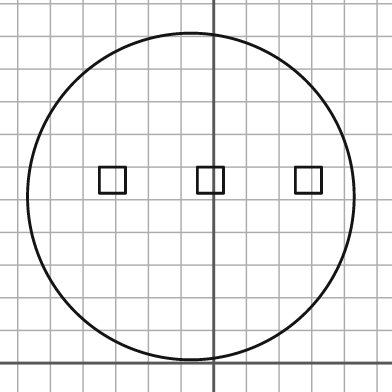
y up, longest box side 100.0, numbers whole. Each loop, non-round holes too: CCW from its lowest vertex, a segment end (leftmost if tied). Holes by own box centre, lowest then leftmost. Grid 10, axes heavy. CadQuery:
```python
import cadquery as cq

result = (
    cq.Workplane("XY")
    .moveTo(-7.0, 51.0)
    .circle(50.0)
    .moveTo(-35.0, 52.0)
    .lineTo(-27.0, 52.0)
    .lineTo(-27.0, 60.0)
    .lineTo(-35.0, 60.0)
    .close()
    .moveTo(-5.0, 52.0)
    .lineTo(3.0, 52.0)
    .lineTo(3.0, 60.0)
    .lineTo(-5.0, 60.0)
    .close()
    .moveTo(25.0, 52.0)
    .lineTo(33.0, 52.0)
    .lineTo(33.0, 60.0)
    .lineTo(25.0, 60.0)
    .close()
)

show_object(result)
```